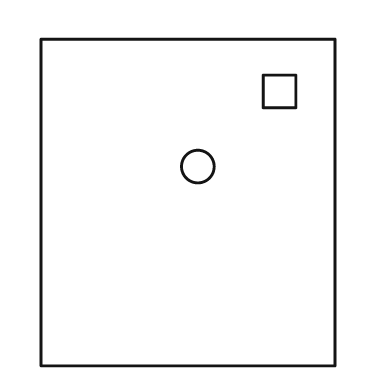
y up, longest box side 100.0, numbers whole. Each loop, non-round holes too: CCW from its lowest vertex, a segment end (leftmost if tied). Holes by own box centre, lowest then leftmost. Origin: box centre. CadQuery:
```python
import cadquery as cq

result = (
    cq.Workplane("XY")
    .moveTo(-45.0, -50.0)
    .lineTo(45.0, -50.0)
    .lineTo(45.0, 50.0)
    .lineTo(-45.0, 50.0)
    .close()
    .moveTo(3.0, 11.0)
    .circle(5.0)
    .moveTo(23.0, 29.0)
    .lineTo(33.0, 29.0)
    .lineTo(33.0, 39.0)
    .lineTo(23.0, 39.0)
    .close()
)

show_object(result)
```